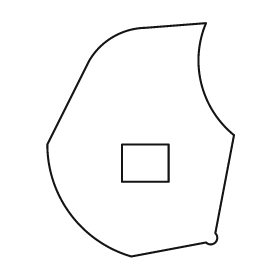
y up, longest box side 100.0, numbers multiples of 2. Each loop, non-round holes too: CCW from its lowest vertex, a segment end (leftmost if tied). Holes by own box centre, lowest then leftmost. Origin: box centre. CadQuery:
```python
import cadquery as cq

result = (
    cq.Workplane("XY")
    .moveTo(-4.0, -50.0)
    .lineTo(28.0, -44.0)
    .threePointArc((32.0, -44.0), (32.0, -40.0))
    .lineTo(40.0, 2.0)
    .threePointArc((26.0, 24.0), (28.0, 50.0))
    .lineTo(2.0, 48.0)
    .threePointArc((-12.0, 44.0), (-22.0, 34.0))
    .lineTo(-40.0, -2.0)
    .threePointArc((-30.0, -32.0), (-4.0, -50.0))
    .close()
    .moveTo(-8.0, -18.0)
    .lineTo(12.0, -18.0)
    .lineTo(12.0, -2.0)
    .lineTo(-8.0, -2.0)
    .close()
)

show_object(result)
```